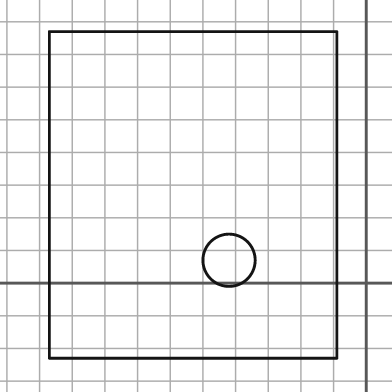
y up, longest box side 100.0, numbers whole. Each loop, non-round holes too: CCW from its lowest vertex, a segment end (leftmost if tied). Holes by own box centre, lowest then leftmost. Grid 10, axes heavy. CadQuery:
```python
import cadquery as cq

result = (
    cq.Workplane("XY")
    .moveTo(-97.0, -23.0)
    .lineTo(-9.0, -23.0)
    .lineTo(-9.0, 77.0)
    .lineTo(-97.0, 77.0)
    .close()
    .moveTo(-42.0, 7.0)
    .circle(8.0)
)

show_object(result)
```